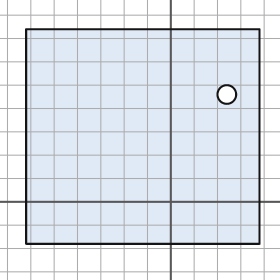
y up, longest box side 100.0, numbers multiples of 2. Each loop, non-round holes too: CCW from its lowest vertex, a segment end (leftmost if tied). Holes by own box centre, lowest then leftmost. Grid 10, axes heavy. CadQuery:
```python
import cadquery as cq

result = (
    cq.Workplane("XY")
    .moveTo(-62.0, -18.0)
    .lineTo(38.0, -18.0)
    .lineTo(38.0, 74.0)
    .lineTo(-62.0, 74.0)
    .close()
    .moveTo(24.0, 46.0)
    .circle(4.0)
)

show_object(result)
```